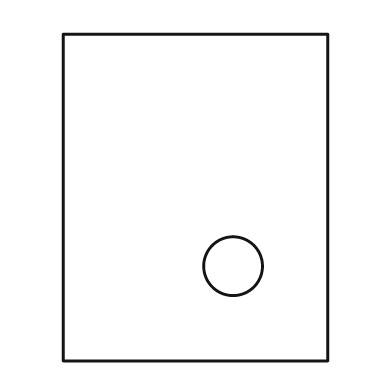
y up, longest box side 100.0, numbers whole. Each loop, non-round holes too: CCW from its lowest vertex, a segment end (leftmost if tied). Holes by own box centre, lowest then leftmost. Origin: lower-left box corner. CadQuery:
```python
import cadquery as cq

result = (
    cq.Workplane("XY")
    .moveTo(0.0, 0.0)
    .lineTo(81.0, 0.0)
    .lineTo(81.0, 100.0)
    .lineTo(0.0, 100.0)
    .close()
    .moveTo(52.0, 29.0)
    .circle(9.0)
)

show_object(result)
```